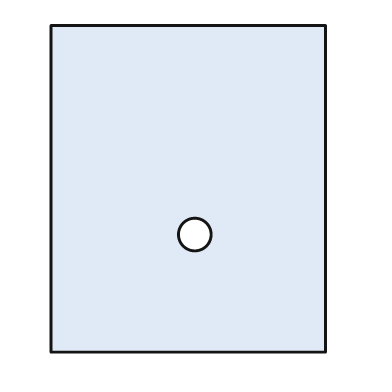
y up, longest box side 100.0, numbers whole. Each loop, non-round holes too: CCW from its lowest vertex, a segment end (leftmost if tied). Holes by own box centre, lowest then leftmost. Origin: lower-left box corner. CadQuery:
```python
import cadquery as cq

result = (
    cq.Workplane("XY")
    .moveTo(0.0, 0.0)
    .lineTo(84.0, 0.0)
    .lineTo(84.0, 100.0)
    .lineTo(0.0, 100.0)
    .close()
    .moveTo(44.0, 36.0)
    .circle(5.0)
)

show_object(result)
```